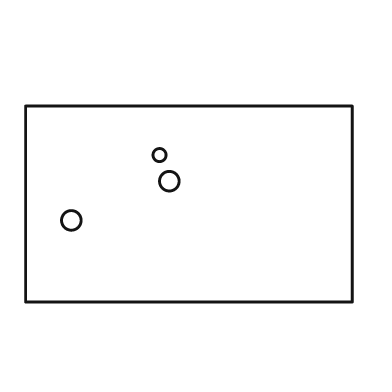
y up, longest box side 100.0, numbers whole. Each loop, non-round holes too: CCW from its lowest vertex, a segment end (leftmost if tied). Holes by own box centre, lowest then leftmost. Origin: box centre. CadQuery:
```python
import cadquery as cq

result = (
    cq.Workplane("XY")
    .moveTo(-50.0, -30.0)
    .lineTo(50.0, -30.0)
    .lineTo(50.0, 30.0)
    .lineTo(-50.0, 30.0)
    .close()
    .moveTo(-36.0, -5.0)
    .circle(3.0)
    .moveTo(-6.0, 7.0)
    .circle(3.0)
    .moveTo(-9.0, 15.0)
    .circle(2.0)
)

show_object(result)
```